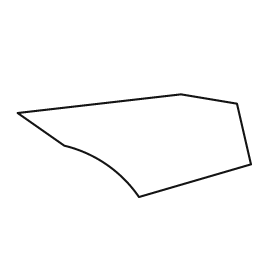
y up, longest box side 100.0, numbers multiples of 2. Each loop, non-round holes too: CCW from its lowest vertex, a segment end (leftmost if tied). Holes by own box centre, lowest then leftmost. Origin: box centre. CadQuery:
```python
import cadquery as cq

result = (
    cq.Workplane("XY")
    .moveTo(2.0, -22.0)
    .lineTo(50.0, -8.0)
    .lineTo(44.0, 18.0)
    .lineTo(20.0, 22.0)
    .lineTo(-50.0, 14.0)
    .lineTo(-30.0, 0.0)
    .threePointArc((-12.0, -8.0), (2.0, -22.0))
    .close()
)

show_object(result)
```